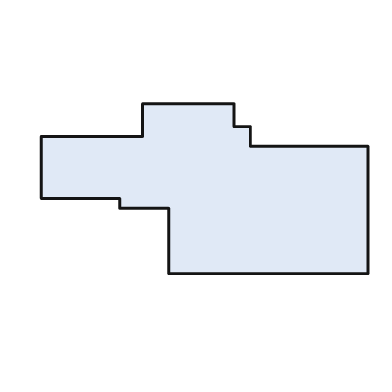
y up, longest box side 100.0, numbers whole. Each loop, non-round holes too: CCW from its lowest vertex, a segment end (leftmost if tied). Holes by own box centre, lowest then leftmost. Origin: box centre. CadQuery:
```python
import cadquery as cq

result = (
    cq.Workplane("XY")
    .moveTo(-11.0, -26.0)
    .lineTo(50.0, -26.0)
    .lineTo(50.0, 13.0)
    .lineTo(14.0, 13.0)
    .lineTo(14.0, 19.0)
    .lineTo(9.0, 19.0)
    .lineTo(9.0, 26.0)
    .lineTo(-19.0, 26.0)
    .lineTo(-19.0, 16.0)
    .lineTo(-50.0, 16.0)
    .lineTo(-50.0, -3.0)
    .lineTo(-26.0, -3.0)
    .lineTo(-26.0, -6.0)
    .lineTo(-11.0, -6.0)
    .close()
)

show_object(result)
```